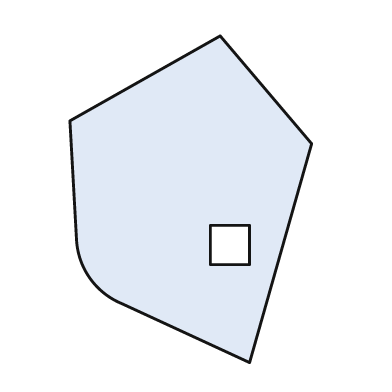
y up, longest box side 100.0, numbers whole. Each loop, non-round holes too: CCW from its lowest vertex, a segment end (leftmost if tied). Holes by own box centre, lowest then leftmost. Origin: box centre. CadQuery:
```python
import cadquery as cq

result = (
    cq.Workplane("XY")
    .moveTo(18.0, -50.0)
    .lineTo(37.0, 17.0)
    .lineTo(9.0, 50.0)
    .lineTo(-37.0, 24.0)
    .lineTo(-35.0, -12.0)
    .threePointArc((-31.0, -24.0), (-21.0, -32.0))
    .close()
    .moveTo(6.0, -20.0)
    .lineTo(18.0, -20.0)
    .lineTo(18.0, -8.0)
    .lineTo(6.0, -8.0)
    .close()
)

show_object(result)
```